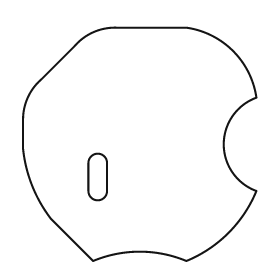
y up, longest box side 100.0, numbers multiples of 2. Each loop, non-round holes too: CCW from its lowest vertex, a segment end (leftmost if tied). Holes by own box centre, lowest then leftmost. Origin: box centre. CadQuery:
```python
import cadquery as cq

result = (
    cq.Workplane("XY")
    .moveTo(-20.0, -50.0)
    .threePointArc((0.0, -46.0), (20.0, -50.0))
    .threePointArc((38.0, -38.0), (50.0, -20.0))
    .threePointArc((36.0, 0.0), (50.0, 20.0))
    .threePointArc((40.0, 40.0), (20.0, 50.0))
    .lineTo(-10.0, 50.0)
    .threePointArc((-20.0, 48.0), (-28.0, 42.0))
    .lineTo(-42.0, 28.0)
    .threePointArc((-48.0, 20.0), (-50.0, 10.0))
    .lineTo(-50.0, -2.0)
    .threePointArc((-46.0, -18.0), (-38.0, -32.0))
    .close()
    .moveTo(-22.0, -20.0)
    .threePointArc((-18.0, -24.0), (-14.0, -20.0))
    .lineTo(-14.0, -8.0)
    .threePointArc((-18.0, -4.0), (-22.0, -8.0))
    .close()
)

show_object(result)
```